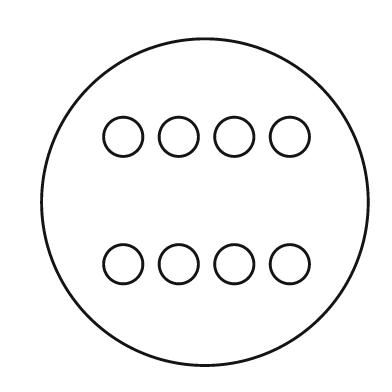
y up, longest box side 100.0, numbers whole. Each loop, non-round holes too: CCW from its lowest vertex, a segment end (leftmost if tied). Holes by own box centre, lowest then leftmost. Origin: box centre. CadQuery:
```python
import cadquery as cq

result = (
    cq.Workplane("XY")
    .moveTo(0.0, 0.0)
    .circle(50.0)
    .moveTo(-25.0, -19.0)
    .circle(6.0)
    .moveTo(-8.0, -19.0)
    .circle(6.0)
    .moveTo(9.0, -19.0)
    .circle(6.0)
    .moveTo(26.0, -19.0)
    .circle(6.0)
    .moveTo(-25.0, 20.0)
    .circle(6.0)
    .moveTo(-8.0, 20.0)
    .circle(6.0)
    .moveTo(9.0, 20.0)
    .circle(6.0)
    .moveTo(26.0, 20.0)
    .circle(6.0)
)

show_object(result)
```